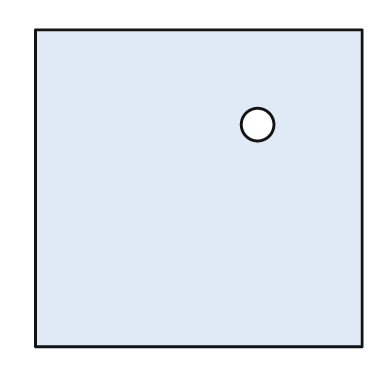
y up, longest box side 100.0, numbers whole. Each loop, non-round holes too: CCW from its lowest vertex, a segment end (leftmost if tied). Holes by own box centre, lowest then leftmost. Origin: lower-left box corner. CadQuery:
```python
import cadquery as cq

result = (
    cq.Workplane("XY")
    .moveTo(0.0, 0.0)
    .lineTo(100.0, 0.0)
    .lineTo(100.0, 97.0)
    .lineTo(0.0, 97.0)
    .close()
    .moveTo(68.0, 68.0)
    .circle(5.0)
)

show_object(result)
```